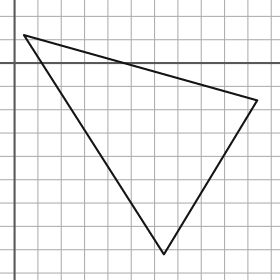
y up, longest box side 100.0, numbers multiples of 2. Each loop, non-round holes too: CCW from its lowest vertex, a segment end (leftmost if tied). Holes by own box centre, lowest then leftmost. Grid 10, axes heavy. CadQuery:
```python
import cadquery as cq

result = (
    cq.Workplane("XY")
    .moveTo(64.0, -82.0)
    .lineTo(104.0, -16.0)
    .lineTo(4.0, 12.0)
    .close()
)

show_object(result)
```